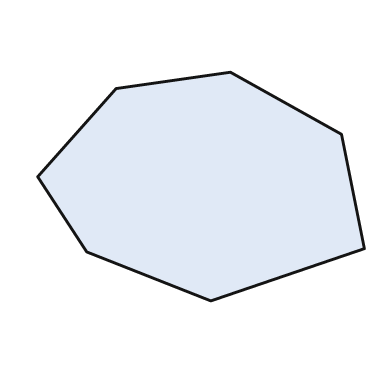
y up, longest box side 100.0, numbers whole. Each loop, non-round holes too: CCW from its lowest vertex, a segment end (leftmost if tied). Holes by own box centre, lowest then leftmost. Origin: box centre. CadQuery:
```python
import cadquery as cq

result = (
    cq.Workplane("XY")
    .moveTo(3.0, -35.0)
    .lineTo(50.0, -19.0)
    .lineTo(43.0, 16.0)
    .lineTo(9.0, 35.0)
    .lineTo(-26.0, 30.0)
    .lineTo(-50.0, 3.0)
    .lineTo(-35.0, -20.0)
    .close()
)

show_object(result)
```